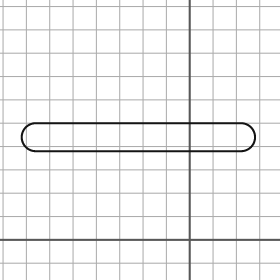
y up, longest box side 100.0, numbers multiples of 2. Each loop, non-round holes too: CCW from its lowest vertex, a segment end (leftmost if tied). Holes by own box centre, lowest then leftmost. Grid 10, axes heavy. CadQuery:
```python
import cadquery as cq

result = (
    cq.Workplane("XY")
    .moveTo(-66.0, 38.0)
    .lineTo(22.0, 38.0)
    .threePointArc((28.0, 44.0), (22.0, 50.0))
    .lineTo(-66.0, 50.0)
    .threePointArc((-72.0, 44.0), (-66.0, 38.0))
    .close()
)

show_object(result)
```